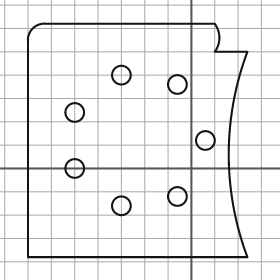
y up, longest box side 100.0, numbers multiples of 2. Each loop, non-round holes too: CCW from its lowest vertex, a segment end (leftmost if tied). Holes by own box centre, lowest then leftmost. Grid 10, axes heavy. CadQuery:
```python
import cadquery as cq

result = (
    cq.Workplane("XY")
    .moveTo(-70.0, -38.0)
    .lineTo(24.0, -38.0)
    .threePointArc((16.0, 6.0), (24.0, 50.0))
    .lineTo(10.0, 50.0)
    .threePointArc((12.0, 56.0), (10.0, 62.0))
    .lineTo(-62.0, 62.0)
    .threePointArc((-68.0, 60.0), (-70.0, 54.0))
    .close()
    .moveTo(-30.0, -16.0)
    .circle(4.0)
    .moveTo(-6.0, -12.0)
    .circle(4.0)
    .moveTo(-50.0, 0.0)
    .circle(4.0)
    .moveTo(6.0, 12.0)
    .circle(4.0)
    .moveTo(-50.0, 24.0)
    .circle(4.0)
    .moveTo(-6.0, 36.0)
    .circle(4.0)
    .moveTo(-30.0, 40.0)
    .circle(4.0)
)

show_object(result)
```